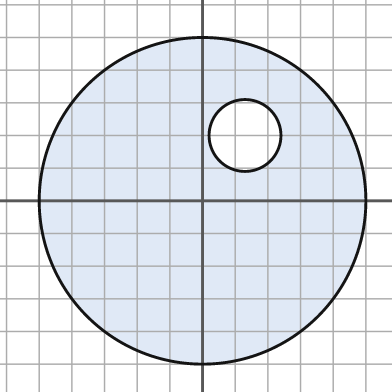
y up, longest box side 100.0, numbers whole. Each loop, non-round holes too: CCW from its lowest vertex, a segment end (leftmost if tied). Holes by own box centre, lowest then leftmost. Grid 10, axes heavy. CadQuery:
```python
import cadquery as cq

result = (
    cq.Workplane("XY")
    .moveTo(0.0, 0.0)
    .circle(50.0)
    .moveTo(13.0, 20.0)
    .circle(11.0)
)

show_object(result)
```